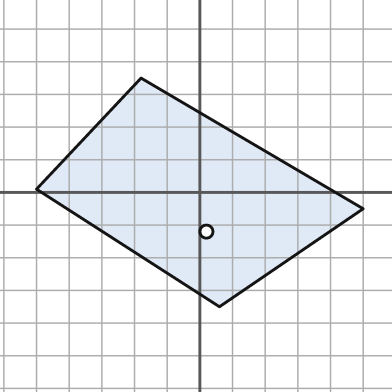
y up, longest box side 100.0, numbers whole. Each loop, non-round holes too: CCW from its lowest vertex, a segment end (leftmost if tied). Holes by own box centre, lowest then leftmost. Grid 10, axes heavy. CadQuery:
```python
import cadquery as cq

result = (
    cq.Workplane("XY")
    .moveTo(6.0, -35.0)
    .lineTo(50.0, -5.0)
    .lineTo(-18.0, 35.0)
    .lineTo(-50.0, 1.0)
    .close()
    .moveTo(2.0, -12.0)
    .circle(2.0)
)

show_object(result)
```